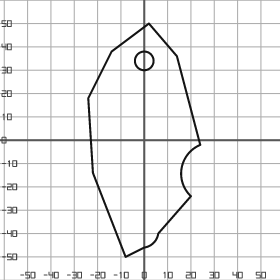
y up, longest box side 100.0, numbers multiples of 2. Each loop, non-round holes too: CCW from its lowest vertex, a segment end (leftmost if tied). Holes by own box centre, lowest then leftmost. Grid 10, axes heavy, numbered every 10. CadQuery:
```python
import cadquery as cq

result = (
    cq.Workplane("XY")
    .moveTo(-8.0, -50.0)
    .lineTo(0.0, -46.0)
    .threePointArc((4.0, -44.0), (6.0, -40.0))
    .lineTo(20.0, -24.0)
    .threePointArc((16.0, -12.0), (24.0, -2.0))
    .lineTo(14.0, 36.0)
    .lineTo(2.0, 50.0)
    .lineTo(-14.0, 38.0)
    .lineTo(-24.0, 18.0)
    .lineTo(-22.0, -14.0)
    .close()
    .moveTo(0.0, 34.0)
    .circle(4.0)
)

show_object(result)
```